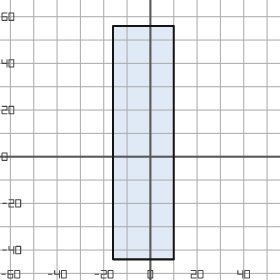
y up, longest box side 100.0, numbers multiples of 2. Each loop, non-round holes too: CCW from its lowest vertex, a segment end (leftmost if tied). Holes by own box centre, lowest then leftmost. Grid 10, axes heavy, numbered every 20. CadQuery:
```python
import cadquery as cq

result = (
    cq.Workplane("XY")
    .moveTo(-16.0, -44.0)
    .lineTo(10.0, -44.0)
    .lineTo(10.0, 56.0)
    .lineTo(-16.0, 56.0)
    .close()
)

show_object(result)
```